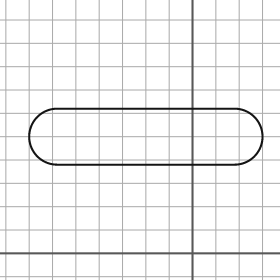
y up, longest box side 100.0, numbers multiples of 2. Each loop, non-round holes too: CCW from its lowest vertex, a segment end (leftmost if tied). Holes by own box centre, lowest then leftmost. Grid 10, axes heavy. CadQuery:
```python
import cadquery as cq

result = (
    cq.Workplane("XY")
    .moveTo(-58.0, 38.0)
    .lineTo(18.0, 38.0)
    .threePointArc((30.0, 50.0), (18.0, 62.0))
    .lineTo(-58.0, 62.0)
    .threePointArc((-70.0, 50.0), (-58.0, 38.0))
    .close()
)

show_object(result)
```